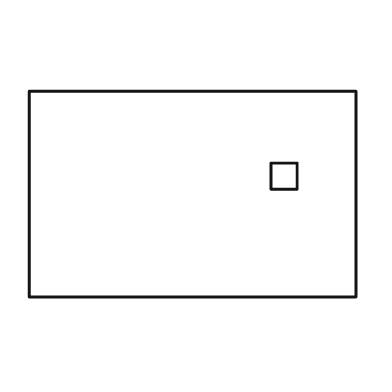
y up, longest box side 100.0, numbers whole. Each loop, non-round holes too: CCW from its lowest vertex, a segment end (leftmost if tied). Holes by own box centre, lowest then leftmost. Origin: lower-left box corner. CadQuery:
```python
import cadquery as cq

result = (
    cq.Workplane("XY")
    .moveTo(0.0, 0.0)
    .lineTo(100.0, 0.0)
    .lineTo(100.0, 63.0)
    .lineTo(0.0, 63.0)
    .close()
    .moveTo(74.0, 33.0)
    .lineTo(82.0, 33.0)
    .lineTo(82.0, 41.0)
    .lineTo(74.0, 41.0)
    .close()
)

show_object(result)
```